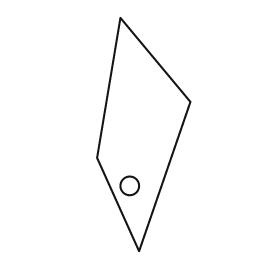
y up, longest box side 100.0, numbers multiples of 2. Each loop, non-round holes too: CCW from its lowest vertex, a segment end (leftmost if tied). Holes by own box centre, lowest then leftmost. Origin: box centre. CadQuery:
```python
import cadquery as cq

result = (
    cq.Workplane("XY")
    .moveTo(-2.0, -50.0)
    .lineTo(20.0, 14.0)
    .lineTo(-10.0, 50.0)
    .lineTo(-20.0, -10.0)
    .close()
    .moveTo(-6.0, -22.0)
    .circle(4.0)
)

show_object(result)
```